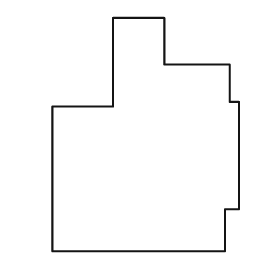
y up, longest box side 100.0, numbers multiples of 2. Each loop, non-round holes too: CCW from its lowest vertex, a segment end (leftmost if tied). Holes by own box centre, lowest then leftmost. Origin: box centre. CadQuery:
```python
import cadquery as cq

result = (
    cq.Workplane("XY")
    .moveTo(-40.0, -50.0)
    .lineTo(34.0, -50.0)
    .lineTo(34.0, -32.0)
    .lineTo(40.0, -32.0)
    .lineTo(40.0, 14.0)
    .lineTo(36.0, 14.0)
    .lineTo(36.0, 30.0)
    .lineTo(8.0, 30.0)
    .lineTo(8.0, 50.0)
    .lineTo(-14.0, 50.0)
    .lineTo(-14.0, 12.0)
    .lineTo(-40.0, 12.0)
    .close()
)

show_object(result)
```